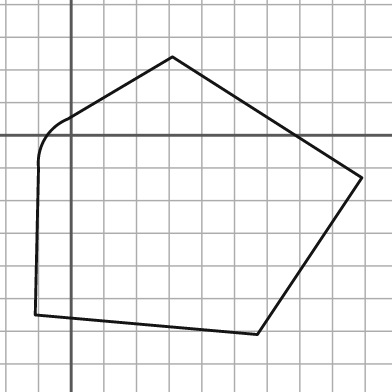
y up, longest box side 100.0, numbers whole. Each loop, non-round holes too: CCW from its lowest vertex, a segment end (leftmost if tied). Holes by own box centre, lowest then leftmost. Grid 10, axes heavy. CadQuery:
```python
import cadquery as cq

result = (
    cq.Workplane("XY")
    .moveTo(57.0, -61.0)
    .lineTo(89.0, -13.0)
    .lineTo(31.0, 24.0)
    .lineTo(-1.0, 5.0)
    .threePointArc((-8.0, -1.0), (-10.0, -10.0))
    .lineTo(-11.0, -55.0)
    .close()
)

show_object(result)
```